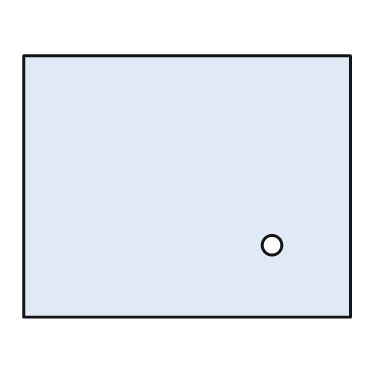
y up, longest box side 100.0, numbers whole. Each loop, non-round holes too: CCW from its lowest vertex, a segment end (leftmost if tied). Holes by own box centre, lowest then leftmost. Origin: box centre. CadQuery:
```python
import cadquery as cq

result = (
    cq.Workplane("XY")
    .moveTo(-50.0, -40.0)
    .lineTo(50.0, -40.0)
    .lineTo(50.0, 40.0)
    .lineTo(-50.0, 40.0)
    .close()
    .moveTo(26.0, -18.0)
    .circle(3.0)
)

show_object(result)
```